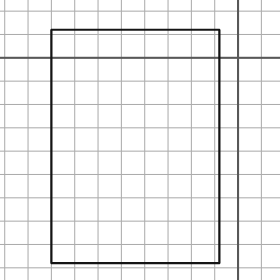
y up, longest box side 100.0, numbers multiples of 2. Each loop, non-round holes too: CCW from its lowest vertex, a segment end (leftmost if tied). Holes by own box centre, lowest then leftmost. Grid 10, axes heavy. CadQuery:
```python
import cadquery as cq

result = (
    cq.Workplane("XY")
    .moveTo(-80.0, -88.0)
    .lineTo(-8.0, -88.0)
    .lineTo(-8.0, 12.0)
    .lineTo(-80.0, 12.0)
    .close()
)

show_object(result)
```